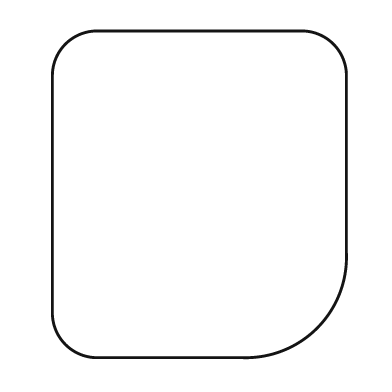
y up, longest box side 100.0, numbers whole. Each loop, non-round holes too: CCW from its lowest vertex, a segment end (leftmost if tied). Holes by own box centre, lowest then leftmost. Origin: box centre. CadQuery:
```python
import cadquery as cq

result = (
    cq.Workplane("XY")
    .moveTo(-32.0, -50.0)
    .lineTo(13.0, -50.0)
    .threePointArc((36.0, -41.0), (45.0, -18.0))
    .lineTo(45.0, 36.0)
    .threePointArc((41.0, 46.0), (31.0, 50.0))
    .lineTo(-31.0, 50.0)
    .threePointArc((-41.0, 46.0), (-45.0, 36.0))
    .lineTo(-45.0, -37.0)
    .threePointArc((-41.0, -46.0), (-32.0, -50.0))
    .close()
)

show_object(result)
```